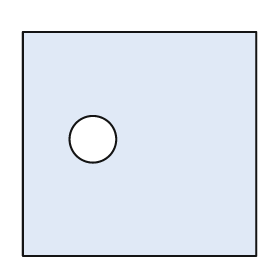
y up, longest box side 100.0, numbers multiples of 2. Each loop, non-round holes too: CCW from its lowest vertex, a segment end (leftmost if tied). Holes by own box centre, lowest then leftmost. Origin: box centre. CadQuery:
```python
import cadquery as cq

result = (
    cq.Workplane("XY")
    .moveTo(-50.0, -48.0)
    .lineTo(50.0, -48.0)
    .lineTo(50.0, 48.0)
    .lineTo(-50.0, 48.0)
    .close()
    .moveTo(-20.0, 2.0)
    .circle(10.0)
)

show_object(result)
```